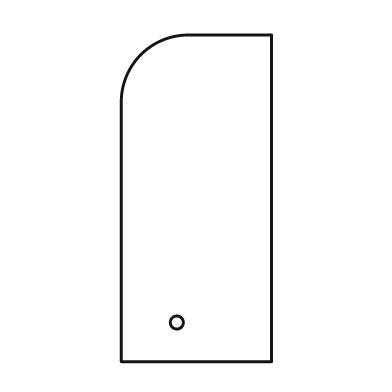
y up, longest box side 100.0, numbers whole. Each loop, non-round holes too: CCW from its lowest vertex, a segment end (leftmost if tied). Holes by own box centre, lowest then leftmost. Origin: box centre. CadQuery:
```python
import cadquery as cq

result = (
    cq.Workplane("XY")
    .moveTo(-23.0, -50.0)
    .lineTo(23.0, -50.0)
    .lineTo(23.0, 50.0)
    .lineTo(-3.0, 50.0)
    .threePointArc((-17.0, 44.0), (-23.0, 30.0))
    .close()
    .moveTo(-6.0, -38.0)
    .circle(2.0)
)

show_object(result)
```